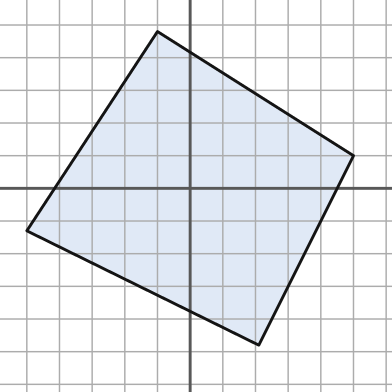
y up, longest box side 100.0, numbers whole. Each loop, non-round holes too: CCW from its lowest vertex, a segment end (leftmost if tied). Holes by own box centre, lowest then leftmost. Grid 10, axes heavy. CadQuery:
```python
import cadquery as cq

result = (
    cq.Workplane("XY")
    .moveTo(21.0, -48.0)
    .lineTo(50.0, 10.0)
    .lineTo(-10.0, 48.0)
    .lineTo(-50.0, -13.0)
    .close()
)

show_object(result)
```